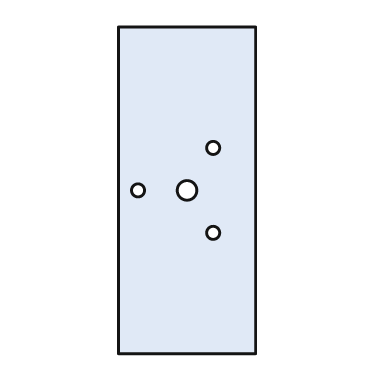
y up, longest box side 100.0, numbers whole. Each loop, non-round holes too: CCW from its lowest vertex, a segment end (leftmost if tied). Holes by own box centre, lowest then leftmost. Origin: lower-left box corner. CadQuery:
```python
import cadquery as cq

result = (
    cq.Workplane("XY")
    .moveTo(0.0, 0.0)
    .lineTo(42.0, 0.0)
    .lineTo(42.0, 100.0)
    .lineTo(0.0, 100.0)
    .close()
    .moveTo(29.0, 37.0)
    .circle(2.0)
    .moveTo(6.0, 50.0)
    .circle(2.0)
    .moveTo(21.0, 50.0)
    .circle(3.0)
    .moveTo(29.0, 63.0)
    .circle(2.0)
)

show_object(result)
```